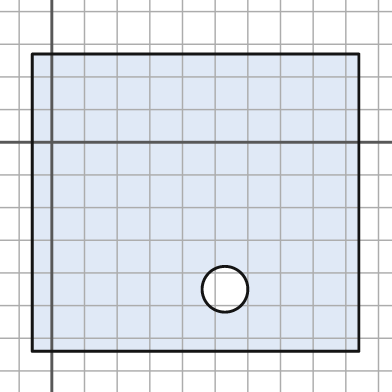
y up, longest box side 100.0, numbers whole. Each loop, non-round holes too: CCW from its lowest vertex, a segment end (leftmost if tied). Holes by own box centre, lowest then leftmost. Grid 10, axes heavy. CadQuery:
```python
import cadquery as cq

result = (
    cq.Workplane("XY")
    .moveTo(-6.0, -64.0)
    .lineTo(94.0, -64.0)
    .lineTo(94.0, 27.0)
    .lineTo(-6.0, 27.0)
    .close()
    .moveTo(53.0, -45.0)
    .circle(7.0)
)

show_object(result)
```